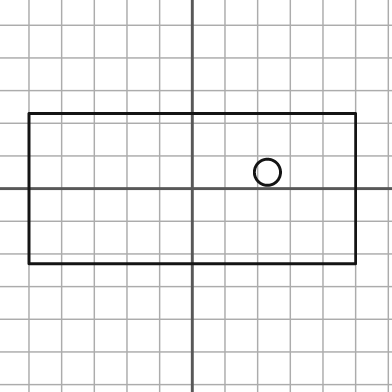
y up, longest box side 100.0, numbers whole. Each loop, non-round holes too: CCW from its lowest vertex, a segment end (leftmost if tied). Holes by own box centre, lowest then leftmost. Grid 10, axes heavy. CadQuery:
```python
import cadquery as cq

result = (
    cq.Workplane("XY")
    .moveTo(-50.0, -23.0)
    .lineTo(50.0, -23.0)
    .lineTo(50.0, 23.0)
    .lineTo(-50.0, 23.0)
    .close()
    .moveTo(23.0, 5.0)
    .circle(4.0)
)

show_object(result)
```